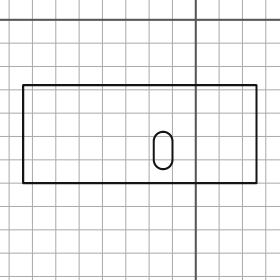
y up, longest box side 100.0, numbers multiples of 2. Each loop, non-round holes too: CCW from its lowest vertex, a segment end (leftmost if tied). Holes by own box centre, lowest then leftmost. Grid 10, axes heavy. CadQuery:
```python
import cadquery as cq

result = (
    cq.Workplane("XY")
    .moveTo(-74.0, -70.0)
    .lineTo(26.0, -70.0)
    .lineTo(26.0, -28.0)
    .lineTo(-74.0, -28.0)
    .close()
    .moveTo(-18.0, -60.0)
    .threePointArc((-14.0, -64.0), (-10.0, -60.0))
    .lineTo(-10.0, -52.0)
    .threePointArc((-14.0, -48.0), (-18.0, -52.0))
    .close()
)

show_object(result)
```